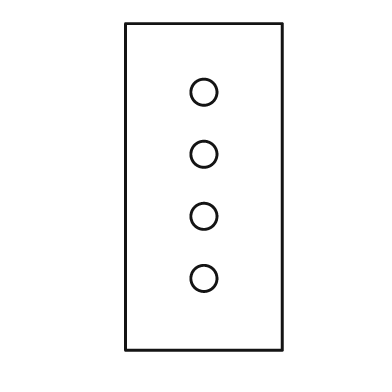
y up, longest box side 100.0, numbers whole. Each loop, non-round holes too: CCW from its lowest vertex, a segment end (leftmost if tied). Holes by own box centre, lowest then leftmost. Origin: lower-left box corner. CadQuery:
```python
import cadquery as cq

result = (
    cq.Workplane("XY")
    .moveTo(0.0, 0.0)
    .lineTo(48.0, 0.0)
    .lineTo(48.0, 100.0)
    .lineTo(0.0, 100.0)
    .close()
    .moveTo(24.0, 22.0)
    .circle(4.0)
    .moveTo(24.0, 41.0)
    .circle(4.0)
    .moveTo(24.0, 60.0)
    .circle(4.0)
    .moveTo(24.0, 79.0)
    .circle(4.0)
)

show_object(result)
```